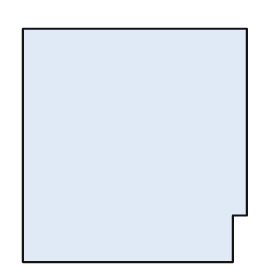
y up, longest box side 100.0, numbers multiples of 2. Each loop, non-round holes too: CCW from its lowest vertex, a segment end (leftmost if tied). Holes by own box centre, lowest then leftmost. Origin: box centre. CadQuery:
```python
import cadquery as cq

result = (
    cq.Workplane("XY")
    .moveTo(-48.0, -50.0)
    .lineTo(42.0, -50.0)
    .lineTo(42.0, -30.0)
    .lineTo(48.0, -30.0)
    .lineTo(48.0, 50.0)
    .lineTo(-48.0, 50.0)
    .close()
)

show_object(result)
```